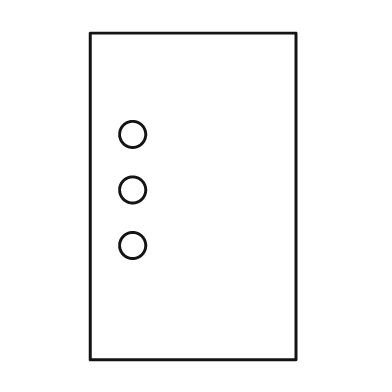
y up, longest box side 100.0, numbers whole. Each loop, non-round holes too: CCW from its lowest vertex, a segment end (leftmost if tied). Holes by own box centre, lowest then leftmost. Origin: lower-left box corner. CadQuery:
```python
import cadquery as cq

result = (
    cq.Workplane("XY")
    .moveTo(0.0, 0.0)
    .lineTo(63.0, 0.0)
    .lineTo(63.0, 100.0)
    .lineTo(0.0, 100.0)
    .close()
    .moveTo(13.0, 35.0)
    .circle(4.0)
    .moveTo(13.0, 52.0)
    .circle(4.0)
    .moveTo(13.0, 69.0)
    .circle(4.0)
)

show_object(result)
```